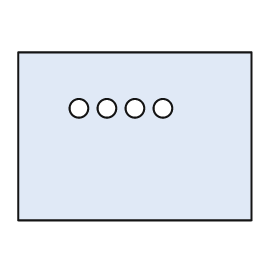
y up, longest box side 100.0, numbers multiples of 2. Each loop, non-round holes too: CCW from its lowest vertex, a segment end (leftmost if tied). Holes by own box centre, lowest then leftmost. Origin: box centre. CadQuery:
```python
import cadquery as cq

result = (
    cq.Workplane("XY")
    .moveTo(-50.0, -36.0)
    .lineTo(50.0, -36.0)
    .lineTo(50.0, 36.0)
    .lineTo(-50.0, 36.0)
    .close()
    .moveTo(-24.0, 12.0)
    .circle(4.0)
    .moveTo(-12.0, 12.0)
    .circle(4.0)
    .moveTo(0.0, 12.0)
    .circle(4.0)
    .moveTo(12.0, 12.0)
    .circle(4.0)
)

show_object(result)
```